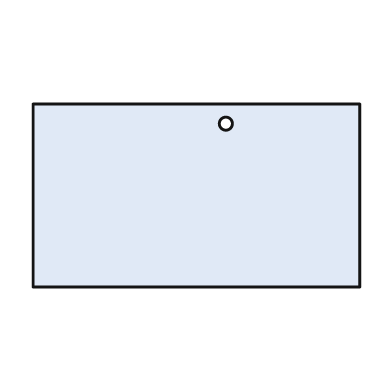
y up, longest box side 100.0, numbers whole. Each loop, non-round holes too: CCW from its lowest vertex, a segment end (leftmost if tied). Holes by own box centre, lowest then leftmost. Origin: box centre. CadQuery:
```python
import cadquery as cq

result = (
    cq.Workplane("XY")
    .moveTo(-50.0, -28.0)
    .lineTo(50.0, -28.0)
    .lineTo(50.0, 28.0)
    .lineTo(-50.0, 28.0)
    .close()
    .moveTo(9.0, 22.0)
    .circle(2.0)
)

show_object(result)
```